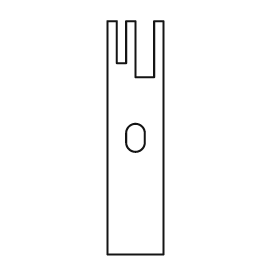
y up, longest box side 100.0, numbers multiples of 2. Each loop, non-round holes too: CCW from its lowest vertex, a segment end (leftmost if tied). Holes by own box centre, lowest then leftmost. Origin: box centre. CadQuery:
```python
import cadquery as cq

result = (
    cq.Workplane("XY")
    .moveTo(-12.0, -50.0)
    .lineTo(12.0, -50.0)
    .lineTo(12.0, 50.0)
    .lineTo(8.0, 50.0)
    .lineTo(8.0, 26.0)
    .lineTo(0.0, 26.0)
    .lineTo(0.0, 50.0)
    .lineTo(-4.0, 50.0)
    .lineTo(-4.0, 32.0)
    .lineTo(-8.0, 32.0)
    .lineTo(-8.0, 50.0)
    .lineTo(-12.0, 50.0)
    .close()
    .moveTo(-4.0, -2.0)
    .threePointArc((0.0, -6.0), (4.0, -2.0))
    .lineTo(4.0, 2.0)
    .threePointArc((0.0, 6.0), (-4.0, 2.0))
    .close()
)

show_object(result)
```